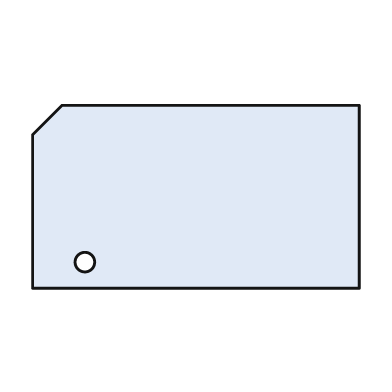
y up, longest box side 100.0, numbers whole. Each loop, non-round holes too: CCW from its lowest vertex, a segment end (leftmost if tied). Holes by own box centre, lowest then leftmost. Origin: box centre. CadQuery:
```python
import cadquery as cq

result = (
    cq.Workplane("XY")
    .moveTo(-50.0, -28.0)
    .lineTo(50.0, -28.0)
    .lineTo(50.0, 28.0)
    .lineTo(-41.0, 28.0)
    .lineTo(-50.0, 19.0)
    .close()
    .moveTo(-34.0, -20.0)
    .circle(3.0)
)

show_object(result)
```